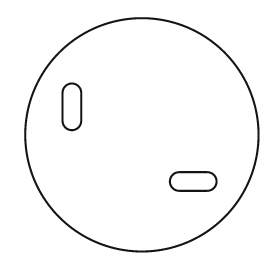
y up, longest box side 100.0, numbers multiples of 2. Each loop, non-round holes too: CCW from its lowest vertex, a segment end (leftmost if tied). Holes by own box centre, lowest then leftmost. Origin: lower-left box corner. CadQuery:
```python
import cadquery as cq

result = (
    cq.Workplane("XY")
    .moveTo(50.0, 50.0)
    .circle(50.0)
    .moveTo(66.0, 26.0)
    .lineTo(78.0, 26.0)
    .threePointArc((82.0, 30.0), (78.0, 34.0))
    .lineTo(66.0, 34.0)
    .threePointArc((62.0, 30.0), (66.0, 26.0))
    .close()
    .moveTo(16.0, 56.0)
    .threePointArc((20.0, 52.0), (24.0, 56.0))
    .lineTo(24.0, 68.0)
    .threePointArc((20.0, 72.0), (16.0, 68.0))
    .close()
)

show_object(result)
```